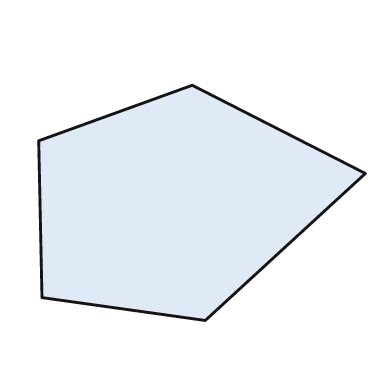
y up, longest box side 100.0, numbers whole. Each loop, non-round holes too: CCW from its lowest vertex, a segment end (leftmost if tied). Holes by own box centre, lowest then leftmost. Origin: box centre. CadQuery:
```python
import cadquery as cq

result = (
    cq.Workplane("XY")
    .moveTo(1.0, -36.0)
    .lineTo(50.0, 9.0)
    .lineTo(-3.0, 36.0)
    .lineTo(-50.0, 19.0)
    .lineTo(-49.0, -29.0)
    .close()
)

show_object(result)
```